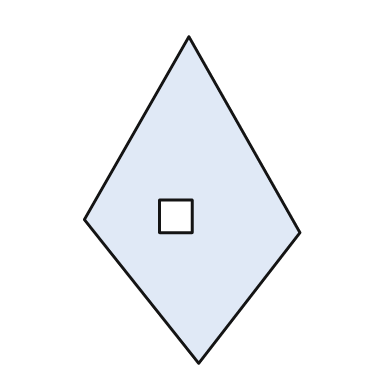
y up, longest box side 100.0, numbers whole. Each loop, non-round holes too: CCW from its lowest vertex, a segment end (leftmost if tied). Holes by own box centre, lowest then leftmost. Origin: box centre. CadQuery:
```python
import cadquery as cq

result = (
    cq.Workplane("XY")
    .moveTo(2.0, -50.0)
    .lineTo(33.0, -10.0)
    .lineTo(-1.0, 50.0)
    .lineTo(-33.0, -6.0)
    .close()
    .moveTo(-10.0, -10.0)
    .lineTo(0.0, -10.0)
    .lineTo(0.0, 0.0)
    .lineTo(-10.0, 0.0)
    .close()
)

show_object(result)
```